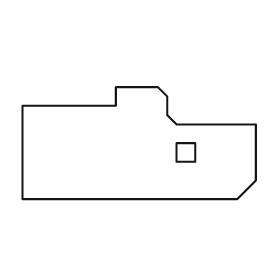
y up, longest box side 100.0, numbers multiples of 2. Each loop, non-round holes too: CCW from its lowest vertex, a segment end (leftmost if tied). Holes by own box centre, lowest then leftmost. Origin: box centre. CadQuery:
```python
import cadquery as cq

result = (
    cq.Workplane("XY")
    .moveTo(-50.0, -24.0)
    .lineTo(42.0, -24.0)
    .lineTo(50.0, -16.0)
    .lineTo(50.0, 8.0)
    .lineTo(16.0, 8.0)
    .lineTo(12.0, 12.0)
    .lineTo(12.0, 20.0)
    .lineTo(8.0, 24.0)
    .lineTo(-10.0, 24.0)
    .lineTo(-10.0, 16.0)
    .lineTo(-50.0, 16.0)
    .close()
    .moveTo(16.0, -8.0)
    .lineTo(24.0, -8.0)
    .lineTo(24.0, 0.0)
    .lineTo(16.0, 0.0)
    .close()
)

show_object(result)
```